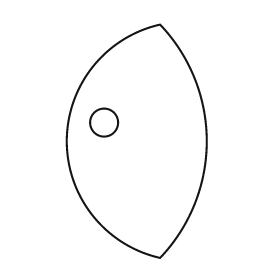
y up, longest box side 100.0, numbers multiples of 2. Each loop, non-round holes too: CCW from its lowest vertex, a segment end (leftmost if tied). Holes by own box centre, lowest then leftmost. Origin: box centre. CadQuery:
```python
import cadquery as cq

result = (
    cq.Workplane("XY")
    .moveTo(10.0, -50.0)
    .threePointArc((30.0, 0.0), (10.0, 50.0))
    .threePointArc((-30.0, 0.0), (10.0, -50.0))
    .close()
    .moveTo(-14.0, 8.0)
    .circle(6.0)
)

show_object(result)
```